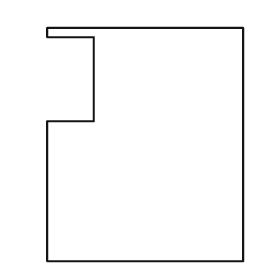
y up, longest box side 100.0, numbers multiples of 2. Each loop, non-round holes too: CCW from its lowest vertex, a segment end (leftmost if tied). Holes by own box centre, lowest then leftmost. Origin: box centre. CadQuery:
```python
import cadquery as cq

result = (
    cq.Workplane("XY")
    .moveTo(-42.0, -50.0)
    .lineTo(42.0, -50.0)
    .lineTo(42.0, 50.0)
    .lineTo(-42.0, 50.0)
    .lineTo(-42.0, 46.0)
    .lineTo(-22.0, 46.0)
    .lineTo(-22.0, 10.0)
    .lineTo(-42.0, 10.0)
    .close()
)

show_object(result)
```